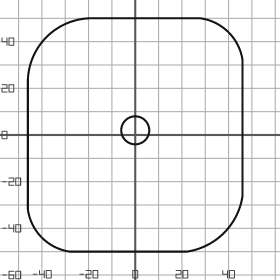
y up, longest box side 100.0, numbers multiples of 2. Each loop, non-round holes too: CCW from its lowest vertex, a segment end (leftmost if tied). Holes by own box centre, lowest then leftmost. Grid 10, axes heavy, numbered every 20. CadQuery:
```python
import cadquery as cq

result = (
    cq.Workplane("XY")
    .moveTo(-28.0, -50.0)
    .lineTo(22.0, -50.0)
    .threePointArc((38.0, -42.0), (46.0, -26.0))
    .lineTo(46.0, 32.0)
    .threePointArc((40.0, 44.0), (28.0, 50.0))
    .lineTo(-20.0, 50.0)
    .threePointArc((-38.0, 42.0), (-46.0, 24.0))
    .lineTo(-46.0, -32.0)
    .threePointArc((-40.0, -44.0), (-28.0, -50.0))
    .close()
    .moveTo(0.0, 2.0)
    .circle(6.0)
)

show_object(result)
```